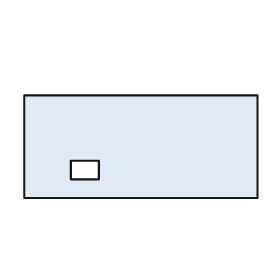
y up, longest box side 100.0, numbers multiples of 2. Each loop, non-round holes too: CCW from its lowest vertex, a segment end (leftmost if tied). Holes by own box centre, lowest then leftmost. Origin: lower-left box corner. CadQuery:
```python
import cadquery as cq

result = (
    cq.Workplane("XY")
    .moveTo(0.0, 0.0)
    .lineTo(100.0, 0.0)
    .lineTo(100.0, 44.0)
    .lineTo(0.0, 44.0)
    .close()
    .moveTo(20.0, 8.0)
    .lineTo(32.0, 8.0)
    .lineTo(32.0, 16.0)
    .lineTo(20.0, 16.0)
    .close()
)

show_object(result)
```